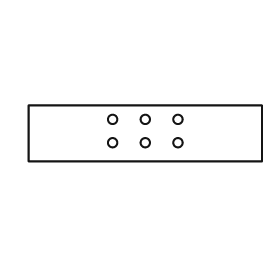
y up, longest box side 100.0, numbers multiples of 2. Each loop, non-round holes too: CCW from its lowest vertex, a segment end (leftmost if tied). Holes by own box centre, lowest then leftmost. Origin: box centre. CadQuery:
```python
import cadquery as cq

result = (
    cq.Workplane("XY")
    .moveTo(-50.0, -12.0)
    .lineTo(50.0, -12.0)
    .lineTo(50.0, 12.0)
    .lineTo(-50.0, 12.0)
    .close()
    .moveTo(-14.0, -4.0)
    .circle(2.0)
    .moveTo(0.0, -4.0)
    .circle(2.0)
    .moveTo(14.0, -4.0)
    .circle(2.0)
    .moveTo(-14.0, 6.0)
    .circle(2.0)
    .moveTo(0.0, 6.0)
    .circle(2.0)
    .moveTo(14.0, 6.0)
    .circle(2.0)
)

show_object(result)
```